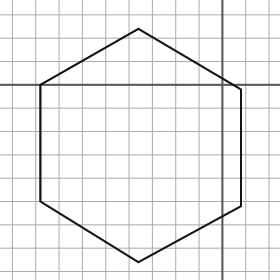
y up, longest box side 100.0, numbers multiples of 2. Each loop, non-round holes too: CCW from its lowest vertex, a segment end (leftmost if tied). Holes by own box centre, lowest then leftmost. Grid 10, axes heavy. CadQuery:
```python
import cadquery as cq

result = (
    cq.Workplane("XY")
    .moveTo(-36.0, -76.0)
    .lineTo(8.0, -52.0)
    .lineTo(8.0, -2.0)
    .lineTo(-36.0, 24.0)
    .lineTo(-78.0, 0.0)
    .lineTo(-78.0, -50.0)
    .close()
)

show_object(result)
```